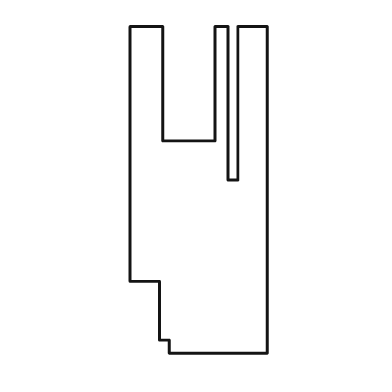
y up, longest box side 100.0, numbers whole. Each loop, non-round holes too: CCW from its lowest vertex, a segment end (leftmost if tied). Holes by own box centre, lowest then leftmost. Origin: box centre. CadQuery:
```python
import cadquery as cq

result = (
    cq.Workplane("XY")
    .moveTo(-9.0, -50.0)
    .lineTo(21.0, -50.0)
    .lineTo(21.0, 50.0)
    .lineTo(12.0, 50.0)
    .lineTo(12.0, 3.0)
    .lineTo(9.0, 3.0)
    .lineTo(9.0, 50.0)
    .lineTo(5.0, 50.0)
    .lineTo(5.0, 15.0)
    .lineTo(-11.0, 15.0)
    .lineTo(-11.0, 50.0)
    .lineTo(-21.0, 50.0)
    .lineTo(-21.0, -28.0)
    .lineTo(-12.0, -28.0)
    .lineTo(-12.0, -46.0)
    .lineTo(-9.0, -46.0)
    .close()
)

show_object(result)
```